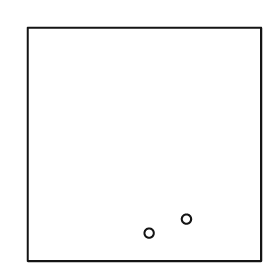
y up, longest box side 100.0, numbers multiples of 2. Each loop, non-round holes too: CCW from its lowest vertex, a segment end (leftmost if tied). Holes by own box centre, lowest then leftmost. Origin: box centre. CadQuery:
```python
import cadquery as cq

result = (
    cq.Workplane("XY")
    .moveTo(-50.0, -50.0)
    .lineTo(50.0, -50.0)
    .lineTo(50.0, 50.0)
    .lineTo(-50.0, 50.0)
    .close()
    .moveTo(2.0, -38.0)
    .circle(2.0)
    .moveTo(18.0, -32.0)
    .circle(2.0)
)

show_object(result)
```